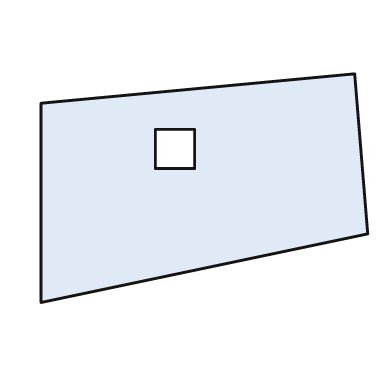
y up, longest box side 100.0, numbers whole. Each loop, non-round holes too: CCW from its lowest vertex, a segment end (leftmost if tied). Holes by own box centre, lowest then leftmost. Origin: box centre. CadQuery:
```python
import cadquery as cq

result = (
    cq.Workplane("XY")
    .moveTo(-50.0, -35.0)
    .lineTo(50.0, -14.0)
    .lineTo(46.0, 35.0)
    .lineTo(-50.0, 26.0)
    .close()
    .moveTo(-15.0, 6.0)
    .lineTo(-3.0, 6.0)
    .lineTo(-3.0, 18.0)
    .lineTo(-15.0, 18.0)
    .close()
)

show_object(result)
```